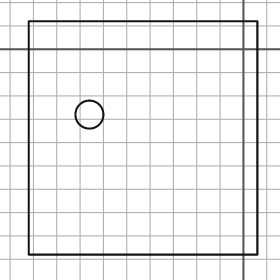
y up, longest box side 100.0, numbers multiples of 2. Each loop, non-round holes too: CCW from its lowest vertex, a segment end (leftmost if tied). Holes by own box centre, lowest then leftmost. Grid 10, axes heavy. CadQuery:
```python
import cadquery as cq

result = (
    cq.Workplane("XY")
    .moveTo(-92.0, -88.0)
    .lineTo(6.0, -88.0)
    .lineTo(6.0, 12.0)
    .lineTo(-92.0, 12.0)
    .close()
    .moveTo(-66.0, -28.0)
    .circle(6.0)
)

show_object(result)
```